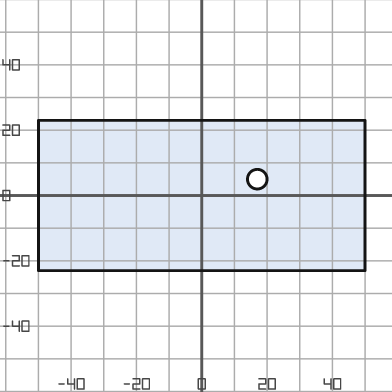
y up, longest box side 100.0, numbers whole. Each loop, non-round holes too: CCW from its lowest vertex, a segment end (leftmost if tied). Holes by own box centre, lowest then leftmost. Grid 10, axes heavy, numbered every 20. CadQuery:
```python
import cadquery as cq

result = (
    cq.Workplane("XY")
    .moveTo(-50.0, -23.0)
    .lineTo(50.0, -23.0)
    .lineTo(50.0, 23.0)
    .lineTo(-50.0, 23.0)
    .close()
    .moveTo(17.0, 5.0)
    .circle(3.0)
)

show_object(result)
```